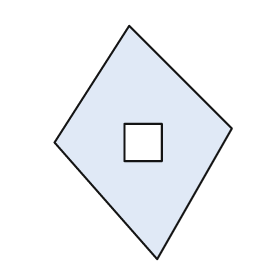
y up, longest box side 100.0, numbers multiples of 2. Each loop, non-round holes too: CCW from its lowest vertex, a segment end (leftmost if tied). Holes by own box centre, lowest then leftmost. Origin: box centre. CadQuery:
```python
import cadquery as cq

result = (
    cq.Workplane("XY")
    .moveTo(6.0, -50.0)
    .lineTo(38.0, 6.0)
    .lineTo(-6.0, 50.0)
    .lineTo(-38.0, 0.0)
    .close()
    .moveTo(-8.0, -8.0)
    .lineTo(8.0, -8.0)
    .lineTo(8.0, 8.0)
    .lineTo(-8.0, 8.0)
    .close()
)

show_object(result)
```